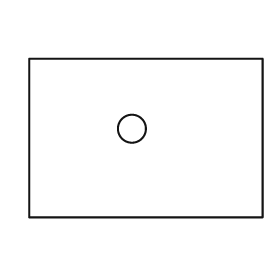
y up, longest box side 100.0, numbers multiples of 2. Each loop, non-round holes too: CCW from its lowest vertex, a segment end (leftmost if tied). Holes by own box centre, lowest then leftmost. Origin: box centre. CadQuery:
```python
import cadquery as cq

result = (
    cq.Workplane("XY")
    .moveTo(-50.0, -34.0)
    .lineTo(50.0, -34.0)
    .lineTo(50.0, 34.0)
    .lineTo(-50.0, 34.0)
    .close()
    .moveTo(-6.0, 4.0)
    .circle(6.0)
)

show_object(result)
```